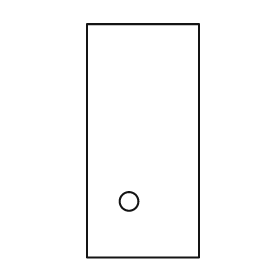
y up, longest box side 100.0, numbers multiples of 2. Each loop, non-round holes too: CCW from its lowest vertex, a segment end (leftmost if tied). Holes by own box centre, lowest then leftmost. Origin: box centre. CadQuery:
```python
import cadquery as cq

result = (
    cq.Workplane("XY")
    .moveTo(-24.0, -50.0)
    .lineTo(24.0, -50.0)
    .lineTo(24.0, 50.0)
    .lineTo(-24.0, 50.0)
    .close()
    .moveTo(-6.0, -26.0)
    .circle(4.0)
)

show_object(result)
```